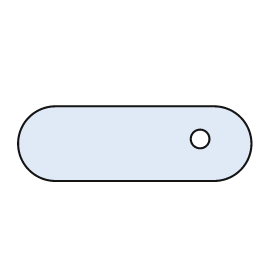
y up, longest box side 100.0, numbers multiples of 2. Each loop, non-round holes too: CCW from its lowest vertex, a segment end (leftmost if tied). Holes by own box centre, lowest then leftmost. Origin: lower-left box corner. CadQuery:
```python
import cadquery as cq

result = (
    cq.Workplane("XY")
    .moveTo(16.0, 0.0)
    .lineTo(84.0, 0.0)
    .threePointArc((100.0, 16.0), (84.0, 32.0))
    .lineTo(16.0, 32.0)
    .threePointArc((0.0, 16.0), (16.0, 0.0))
    .close()
    .moveTo(78.0, 18.0)
    .circle(4.0)
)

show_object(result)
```